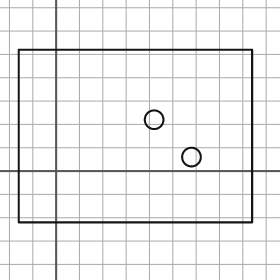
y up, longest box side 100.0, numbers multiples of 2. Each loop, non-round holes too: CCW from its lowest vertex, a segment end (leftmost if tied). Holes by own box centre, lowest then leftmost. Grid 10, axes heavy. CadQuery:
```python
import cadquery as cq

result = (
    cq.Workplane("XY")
    .moveTo(-16.0, -22.0)
    .lineTo(84.0, -22.0)
    .lineTo(84.0, 52.0)
    .lineTo(-16.0, 52.0)
    .close()
    .moveTo(58.0, 6.0)
    .circle(4.0)
    .moveTo(42.0, 22.0)
    .circle(4.0)
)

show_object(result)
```